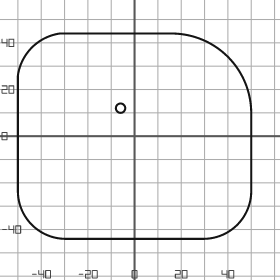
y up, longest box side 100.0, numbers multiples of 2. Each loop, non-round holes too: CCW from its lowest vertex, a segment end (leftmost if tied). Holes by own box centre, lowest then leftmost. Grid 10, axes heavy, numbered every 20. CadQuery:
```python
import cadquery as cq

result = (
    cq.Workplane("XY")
    .moveTo(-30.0, -44.0)
    .lineTo(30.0, -44.0)
    .threePointArc((44.0, -38.0), (50.0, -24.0))
    .lineTo(50.0, 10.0)
    .threePointArc((40.0, 34.0), (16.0, 44.0))
    .lineTo(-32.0, 44.0)
    .threePointArc((-44.0, 38.0), (-50.0, 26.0))
    .lineTo(-50.0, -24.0)
    .threePointArc((-44.0, -38.0), (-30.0, -44.0))
    .close()
    .moveTo(-6.0, 12.0)
    .circle(2.0)
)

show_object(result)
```